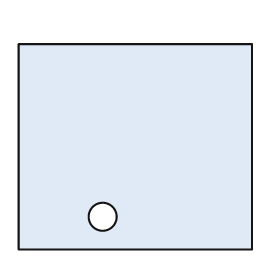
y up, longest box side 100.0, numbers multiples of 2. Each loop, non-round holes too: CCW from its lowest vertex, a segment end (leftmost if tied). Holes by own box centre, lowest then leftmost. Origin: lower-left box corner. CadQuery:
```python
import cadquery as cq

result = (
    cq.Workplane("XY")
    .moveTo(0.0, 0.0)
    .lineTo(100.0, 0.0)
    .lineTo(100.0, 88.0)
    .lineTo(0.0, 88.0)
    .close()
    .moveTo(36.0, 14.0)
    .circle(6.0)
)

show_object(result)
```